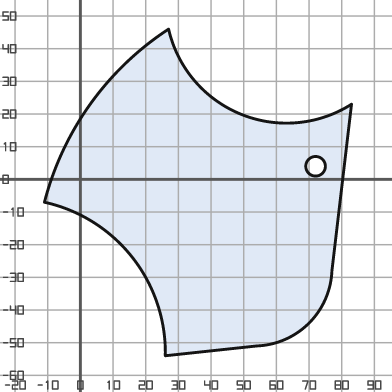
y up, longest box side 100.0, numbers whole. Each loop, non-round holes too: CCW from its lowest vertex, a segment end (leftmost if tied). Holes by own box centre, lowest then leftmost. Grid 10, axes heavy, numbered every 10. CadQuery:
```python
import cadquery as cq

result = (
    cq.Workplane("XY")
    .moveTo(26.0, -54.0)
    .lineTo(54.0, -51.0)
    .threePointArc((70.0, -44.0), (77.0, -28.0))
    .lineTo(83.0, 23.0)
    .threePointArc((49.0, 20.0), (27.0, 46.0))
    .threePointArc((3.0, 23.0), (-11.0, -7.0))
    .threePointArc((16.0, -24.0), (26.0, -54.0))
    .close()
    .moveTo(72.0, 4.0)
    .circle(3.0)
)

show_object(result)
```